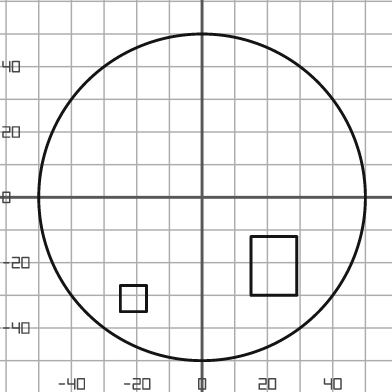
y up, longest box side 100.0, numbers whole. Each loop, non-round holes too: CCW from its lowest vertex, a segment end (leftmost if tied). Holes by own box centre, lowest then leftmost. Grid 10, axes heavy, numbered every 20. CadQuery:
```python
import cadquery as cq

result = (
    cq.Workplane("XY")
    .moveTo(0.0, 0.0)
    .circle(50.0)
    .moveTo(-25.0, -35.0)
    .lineTo(-17.0, -35.0)
    .lineTo(-17.0, -27.0)
    .lineTo(-25.0, -27.0)
    .close()
    .moveTo(15.0, -30.0)
    .lineTo(29.0, -30.0)
    .lineTo(29.0, -12.0)
    .lineTo(15.0, -12.0)
    .close()
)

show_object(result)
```